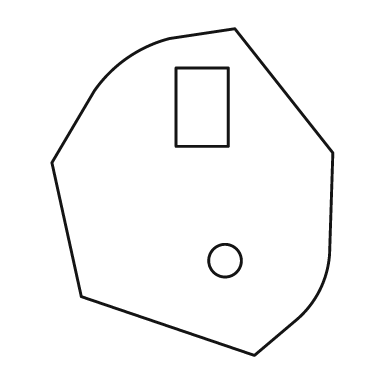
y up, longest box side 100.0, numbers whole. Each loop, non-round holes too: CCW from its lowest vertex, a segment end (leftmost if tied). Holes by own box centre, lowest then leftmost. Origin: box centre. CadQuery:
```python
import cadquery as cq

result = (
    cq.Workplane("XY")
    .moveTo(19.0, -50.0)
    .lineTo(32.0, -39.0)
    .threePointArc((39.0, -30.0), (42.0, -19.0))
    .lineTo(43.0, 12.0)
    .lineTo(13.0, 50.0)
    .lineTo(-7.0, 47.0)
    .threePointArc((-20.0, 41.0), (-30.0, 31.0))
    .lineTo(-43.0, 9.0)
    .lineTo(-34.0, -32.0)
    .close()
    .moveTo(10.0, -21.0)
    .circle(5.0)
    .moveTo(-5.0, 14.0)
    .lineTo(11.0, 14.0)
    .lineTo(11.0, 38.0)
    .lineTo(-5.0, 38.0)
    .close()
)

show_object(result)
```